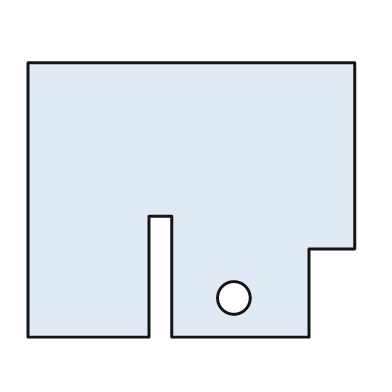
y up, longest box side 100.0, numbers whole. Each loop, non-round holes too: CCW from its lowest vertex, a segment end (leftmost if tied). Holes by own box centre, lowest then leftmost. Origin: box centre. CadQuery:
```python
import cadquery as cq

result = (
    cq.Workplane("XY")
    .moveTo(-50.0, -42.0)
    .lineTo(-13.0, -42.0)
    .lineTo(-13.0, -5.0)
    .lineTo(-6.0, -5.0)
    .lineTo(-6.0, -42.0)
    .lineTo(36.0, -42.0)
    .lineTo(36.0, -15.0)
    .lineTo(50.0, -15.0)
    .lineTo(50.0, 42.0)
    .lineTo(-50.0, 42.0)
    .close()
    .moveTo(13.0, -30.0)
    .circle(5.0)
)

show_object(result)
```